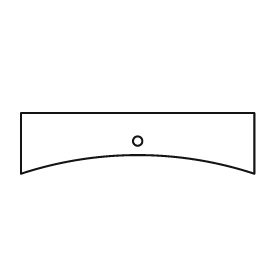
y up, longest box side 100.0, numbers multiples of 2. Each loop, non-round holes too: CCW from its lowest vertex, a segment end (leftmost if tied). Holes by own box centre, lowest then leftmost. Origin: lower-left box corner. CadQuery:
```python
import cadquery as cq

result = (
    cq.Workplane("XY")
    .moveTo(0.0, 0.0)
    .threePointArc((50.0, 8.0), (100.0, 0.0))
    .lineTo(100.0, 26.0)
    .lineTo(0.0, 26.0)
    .close()
    .moveTo(50.0, 14.0)
    .circle(2.0)
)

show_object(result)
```